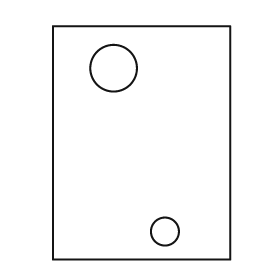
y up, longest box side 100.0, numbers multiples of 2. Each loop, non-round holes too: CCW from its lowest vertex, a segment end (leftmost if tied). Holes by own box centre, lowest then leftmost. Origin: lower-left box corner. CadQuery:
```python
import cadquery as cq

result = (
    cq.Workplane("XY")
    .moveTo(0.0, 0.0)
    .lineTo(76.0, 0.0)
    .lineTo(76.0, 100.0)
    .lineTo(0.0, 100.0)
    .close()
    .moveTo(48.0, 12.0)
    .circle(6.0)
    .moveTo(26.0, 82.0)
    .circle(10.0)
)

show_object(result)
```